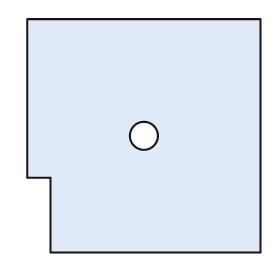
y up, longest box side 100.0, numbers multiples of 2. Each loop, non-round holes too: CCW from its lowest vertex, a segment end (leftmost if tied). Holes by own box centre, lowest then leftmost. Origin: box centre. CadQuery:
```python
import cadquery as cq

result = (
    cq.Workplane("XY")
    .moveTo(-40.0, -50.0)
    .lineTo(50.0, -50.0)
    .lineTo(50.0, 50.0)
    .lineTo(-50.0, 50.0)
    .lineTo(-50.0, -18.0)
    .lineTo(-40.0, -18.0)
    .close()
    .moveTo(0.0, 0.0)
    .circle(6.0)
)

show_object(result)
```